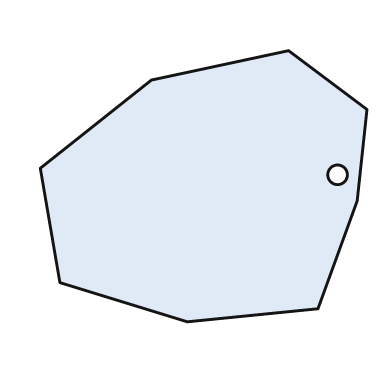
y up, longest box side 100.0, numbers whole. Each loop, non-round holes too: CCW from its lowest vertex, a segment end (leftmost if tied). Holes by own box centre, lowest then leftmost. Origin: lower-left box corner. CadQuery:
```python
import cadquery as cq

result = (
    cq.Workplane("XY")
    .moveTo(45.0, 0.0)
    .lineTo(85.0, 4.0)
    .lineTo(97.0, 37.0)
    .lineTo(100.0, 65.0)
    .lineTo(76.0, 83.0)
    .lineTo(34.0, 74.0)
    .lineTo(0.0, 47.0)
    .lineTo(6.0, 12.0)
    .close()
    .moveTo(91.0, 45.0)
    .circle(3.0)
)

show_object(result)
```